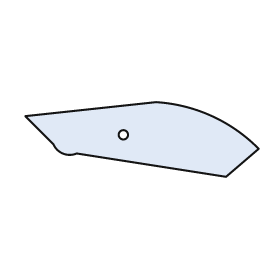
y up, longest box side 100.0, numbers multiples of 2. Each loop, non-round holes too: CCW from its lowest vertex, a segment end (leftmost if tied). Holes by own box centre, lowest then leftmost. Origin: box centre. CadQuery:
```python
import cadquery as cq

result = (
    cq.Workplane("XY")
    .moveTo(36.0, -16.0)
    .lineTo(50.0, -4.0)
    .threePointArc((30.0, 10.0), (6.0, 16.0))
    .lineTo(-50.0, 10.0)
    .lineTo(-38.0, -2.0)
    .threePointArc((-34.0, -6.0), (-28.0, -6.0))
    .close()
    .moveTo(-8.0, 2.0)
    .circle(2.0)
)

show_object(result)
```